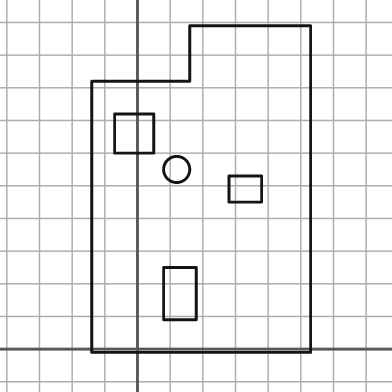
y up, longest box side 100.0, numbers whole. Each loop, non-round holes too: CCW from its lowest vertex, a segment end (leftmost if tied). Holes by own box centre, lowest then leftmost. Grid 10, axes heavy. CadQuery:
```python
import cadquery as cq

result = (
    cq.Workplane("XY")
    .moveTo(-14.0, -1.0)
    .lineTo(53.0, -1.0)
    .lineTo(53.0, 99.0)
    .lineTo(16.0, 99.0)
    .lineTo(16.0, 82.0)
    .lineTo(-14.0, 82.0)
    .close()
    .moveTo(8.0, 9.0)
    .lineTo(18.0, 9.0)
    .lineTo(18.0, 25.0)
    .lineTo(8.0, 25.0)
    .close()
    .moveTo(28.0, 45.0)
    .lineTo(38.0, 45.0)
    .lineTo(38.0, 53.0)
    .lineTo(28.0, 53.0)
    .close()
    .moveTo(12.0, 55.0)
    .circle(4.0)
    .moveTo(-7.0, 60.0)
    .lineTo(5.0, 60.0)
    .lineTo(5.0, 72.0)
    .lineTo(-7.0, 72.0)
    .close()
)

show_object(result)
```